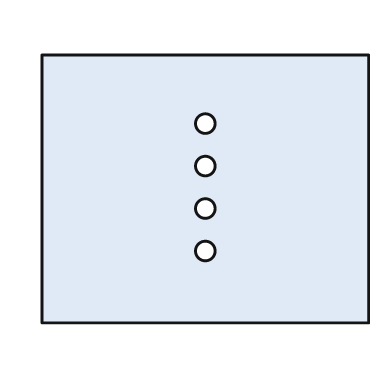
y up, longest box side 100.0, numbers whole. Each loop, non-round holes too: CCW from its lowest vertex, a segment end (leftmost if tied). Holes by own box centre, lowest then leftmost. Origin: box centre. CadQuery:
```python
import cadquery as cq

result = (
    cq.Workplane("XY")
    .moveTo(-50.0, -41.0)
    .lineTo(50.0, -41.0)
    .lineTo(50.0, 41.0)
    .lineTo(-50.0, 41.0)
    .close()
    .moveTo(0.0, -19.0)
    .circle(3.0)
    .moveTo(0.0, -6.0)
    .circle(3.0)
    .moveTo(0.0, 7.0)
    .circle(3.0)
    .moveTo(0.0, 20.0)
    .circle(3.0)
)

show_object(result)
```